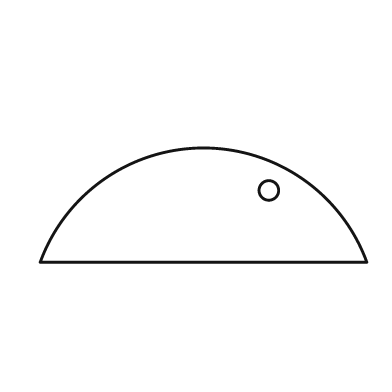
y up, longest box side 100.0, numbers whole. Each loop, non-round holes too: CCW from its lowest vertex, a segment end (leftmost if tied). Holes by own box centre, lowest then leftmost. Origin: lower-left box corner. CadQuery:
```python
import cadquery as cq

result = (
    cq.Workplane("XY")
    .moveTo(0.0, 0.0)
    .lineTo(100.0, 0.0)
    .threePointArc((50.0, 35.0), (0.0, 0.0))
    .close()
    .moveTo(70.0, 22.0)
    .circle(3.0)
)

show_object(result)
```